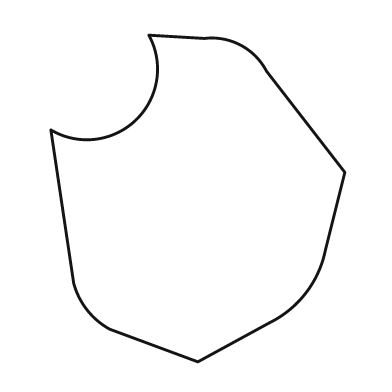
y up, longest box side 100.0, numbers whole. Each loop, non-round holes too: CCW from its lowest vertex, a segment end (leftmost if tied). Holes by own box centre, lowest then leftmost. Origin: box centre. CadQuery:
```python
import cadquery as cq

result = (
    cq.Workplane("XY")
    .moveTo(0.0, -50.0)
    .lineTo(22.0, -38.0)
    .threePointArc((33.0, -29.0), (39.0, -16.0))
    .lineTo(45.0, 8.0)
    .lineTo(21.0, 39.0)
    .threePointArc((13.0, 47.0), (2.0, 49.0))
    .lineTo(-15.0, 50.0)
    .threePointArc((-19.0, 24.0), (-45.0, 21.0))
    .lineTo(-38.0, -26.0)
    .threePointArc((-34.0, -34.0), (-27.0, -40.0))
    .close()
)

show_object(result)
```